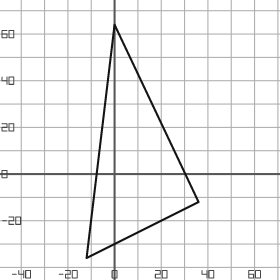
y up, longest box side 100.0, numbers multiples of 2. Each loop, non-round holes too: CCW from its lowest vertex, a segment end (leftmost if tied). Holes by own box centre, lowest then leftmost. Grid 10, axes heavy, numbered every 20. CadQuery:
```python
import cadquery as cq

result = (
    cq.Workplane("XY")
    .moveTo(-12.0, -36.0)
    .lineTo(36.0, -12.0)
    .lineTo(0.0, 64.0)
    .close()
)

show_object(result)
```